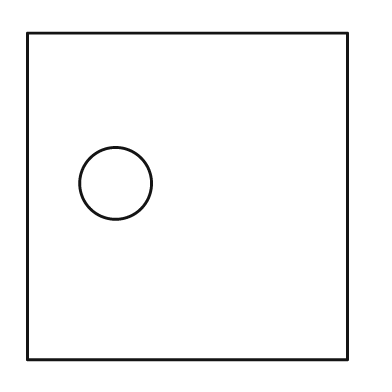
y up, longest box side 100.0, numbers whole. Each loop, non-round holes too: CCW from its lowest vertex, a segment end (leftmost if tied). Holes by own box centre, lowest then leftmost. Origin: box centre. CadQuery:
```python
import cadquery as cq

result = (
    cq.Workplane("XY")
    .moveTo(-49.0, -50.0)
    .lineTo(49.0, -50.0)
    .lineTo(49.0, 50.0)
    .lineTo(-49.0, 50.0)
    .close()
    .moveTo(-22.0, 4.0)
    .circle(11.0)
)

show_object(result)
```